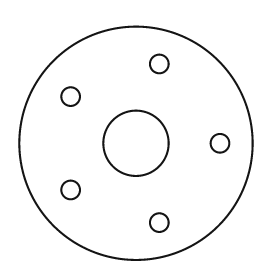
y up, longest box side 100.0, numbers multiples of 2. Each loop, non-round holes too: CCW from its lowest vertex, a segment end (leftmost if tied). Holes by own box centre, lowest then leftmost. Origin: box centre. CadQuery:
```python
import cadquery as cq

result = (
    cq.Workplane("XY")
    .moveTo(0.0, 0.0)
    .circle(50.0)
    .moveTo(10.0, -34.0)
    .circle(4.0)
    .moveTo(-28.0, -20.0)
    .circle(4.0)
    .moveTo(0.0, 0.0)
    .circle(14.0)
    .moveTo(36.0, 0.0)
    .circle(4.0)
    .moveTo(-28.0, 20.0)
    .circle(4.0)
    .moveTo(10.0, 34.0)
    .circle(4.0)
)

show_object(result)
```